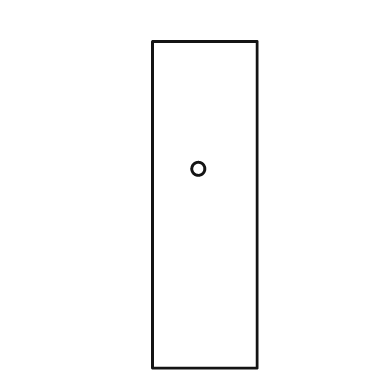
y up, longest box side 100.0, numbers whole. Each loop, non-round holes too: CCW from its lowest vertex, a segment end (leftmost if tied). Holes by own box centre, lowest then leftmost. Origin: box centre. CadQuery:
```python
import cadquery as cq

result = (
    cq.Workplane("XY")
    .moveTo(-16.0, -50.0)
    .lineTo(16.0, -50.0)
    .lineTo(16.0, 50.0)
    .lineTo(-16.0, 50.0)
    .close()
    .moveTo(-2.0, 11.0)
    .circle(2.0)
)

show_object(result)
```